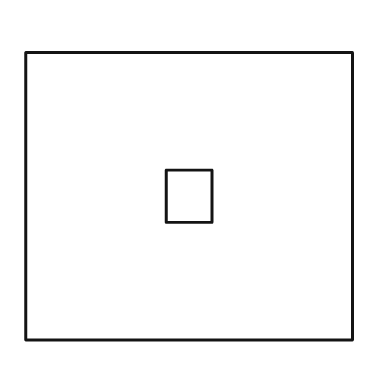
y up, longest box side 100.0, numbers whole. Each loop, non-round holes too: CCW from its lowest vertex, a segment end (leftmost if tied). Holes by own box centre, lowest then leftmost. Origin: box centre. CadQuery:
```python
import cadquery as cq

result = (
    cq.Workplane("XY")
    .moveTo(-50.0, -44.0)
    .lineTo(50.0, -44.0)
    .lineTo(50.0, 44.0)
    .lineTo(-50.0, 44.0)
    .close()
    .moveTo(-7.0, -8.0)
    .lineTo(7.0, -8.0)
    .lineTo(7.0, 8.0)
    .lineTo(-7.0, 8.0)
    .close()
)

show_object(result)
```